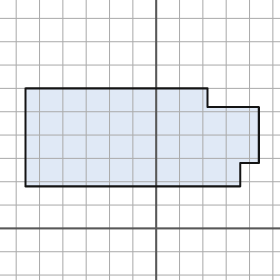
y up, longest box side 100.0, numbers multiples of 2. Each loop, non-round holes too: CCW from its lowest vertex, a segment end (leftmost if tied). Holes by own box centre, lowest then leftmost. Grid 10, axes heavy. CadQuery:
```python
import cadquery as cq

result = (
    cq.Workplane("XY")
    .moveTo(-56.0, 18.0)
    .lineTo(36.0, 18.0)
    .lineTo(36.0, 28.0)
    .lineTo(44.0, 28.0)
    .lineTo(44.0, 52.0)
    .lineTo(22.0, 52.0)
    .lineTo(22.0, 60.0)
    .lineTo(-56.0, 60.0)
    .close()
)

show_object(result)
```